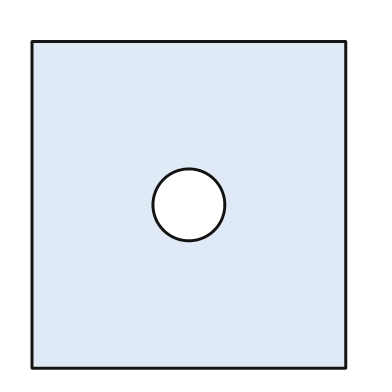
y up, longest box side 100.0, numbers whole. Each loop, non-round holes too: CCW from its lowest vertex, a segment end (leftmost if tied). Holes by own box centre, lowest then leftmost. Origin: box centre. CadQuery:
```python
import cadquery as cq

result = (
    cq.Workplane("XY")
    .moveTo(-48.0, -50.0)
    .lineTo(48.0, -50.0)
    .lineTo(48.0, 50.0)
    .lineTo(-48.0, 50.0)
    .close()
    .moveTo(0.0, 0.0)
    .circle(11.0)
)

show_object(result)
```